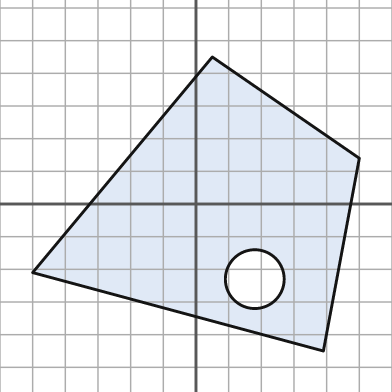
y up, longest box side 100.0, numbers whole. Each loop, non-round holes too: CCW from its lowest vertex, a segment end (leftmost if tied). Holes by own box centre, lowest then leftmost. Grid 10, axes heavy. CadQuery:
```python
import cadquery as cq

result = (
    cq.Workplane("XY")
    .moveTo(39.0, -45.0)
    .lineTo(50.0, 14.0)
    .lineTo(5.0, 45.0)
    .lineTo(-50.0, -21.0)
    .close()
    .moveTo(18.0, -23.0)
    .circle(9.0)
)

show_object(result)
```